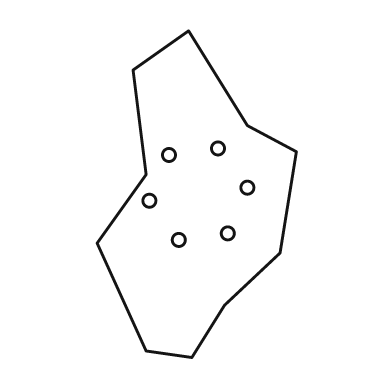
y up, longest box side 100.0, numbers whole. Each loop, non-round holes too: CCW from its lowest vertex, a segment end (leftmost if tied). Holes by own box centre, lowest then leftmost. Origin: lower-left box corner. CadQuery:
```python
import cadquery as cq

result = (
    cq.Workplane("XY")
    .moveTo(29.0, 0.0)
    .lineTo(39.0, 16.0)
    .lineTo(56.0, 32.0)
    .lineTo(61.0, 63.0)
    .lineTo(46.0, 71.0)
    .lineTo(28.0, 100.0)
    .lineTo(11.0, 88.0)
    .lineTo(15.0, 56.0)
    .lineTo(0.0, 35.0)
    .lineTo(15.0, 2.0)
    .close()
    .moveTo(25.0, 36.0)
    .circle(2.0)
    .moveTo(40.0, 38.0)
    .circle(2.0)
    .moveTo(16.0, 48.0)
    .circle(2.0)
    .moveTo(46.0, 52.0)
    .circle(2.0)
    .moveTo(22.0, 62.0)
    .circle(2.0)
    .moveTo(37.0, 64.0)
    .circle(2.0)
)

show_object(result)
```